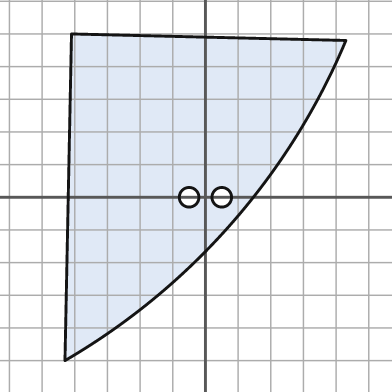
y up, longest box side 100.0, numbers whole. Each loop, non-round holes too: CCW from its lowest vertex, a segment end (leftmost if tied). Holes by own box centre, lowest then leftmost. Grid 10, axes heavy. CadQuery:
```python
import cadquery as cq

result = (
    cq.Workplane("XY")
    .moveTo(-43.0, -50.0)
    .threePointArc((8.0, -8.0), (43.0, 48.0))
    .lineTo(-41.0, 50.0)
    .close()
    .moveTo(-5.0, 0.0)
    .circle(3.0)
    .moveTo(5.0, 0.0)
    .circle(3.0)
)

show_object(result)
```